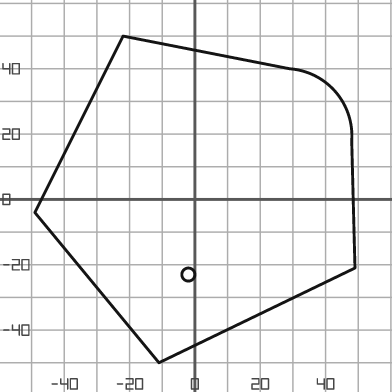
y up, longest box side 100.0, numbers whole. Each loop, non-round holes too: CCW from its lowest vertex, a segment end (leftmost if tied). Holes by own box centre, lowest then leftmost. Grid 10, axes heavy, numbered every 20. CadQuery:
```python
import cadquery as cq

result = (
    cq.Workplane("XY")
    .moveTo(-11.0, -50.0)
    .lineTo(49.0, -21.0)
    .lineTo(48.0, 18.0)
    .threePointArc((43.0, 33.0), (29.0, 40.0))
    .lineTo(-22.0, 50.0)
    .lineTo(-49.0, -4.0)
    .close()
    .moveTo(-2.0, -23.0)
    .circle(2.0)
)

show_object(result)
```